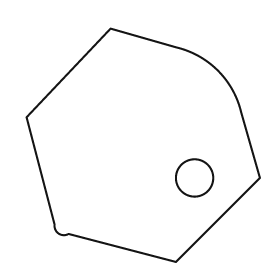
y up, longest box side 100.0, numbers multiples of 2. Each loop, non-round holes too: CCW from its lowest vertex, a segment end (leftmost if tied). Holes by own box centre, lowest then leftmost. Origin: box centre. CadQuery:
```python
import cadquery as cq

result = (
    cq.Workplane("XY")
    .moveTo(14.0, -50.0)
    .lineTo(50.0, -14.0)
    .lineTo(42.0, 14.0)
    .threePointArc((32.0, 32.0), (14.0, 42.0))
    .lineTo(-14.0, 50.0)
    .lineTo(-50.0, 12.0)
    .lineTo(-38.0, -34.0)
    .threePointArc((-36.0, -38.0), (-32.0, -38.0))
    .close()
    .moveTo(22.0, -14.0)
    .circle(8.0)
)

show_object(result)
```